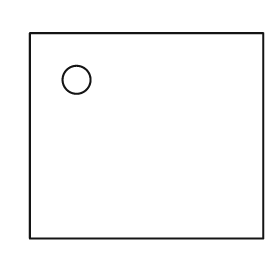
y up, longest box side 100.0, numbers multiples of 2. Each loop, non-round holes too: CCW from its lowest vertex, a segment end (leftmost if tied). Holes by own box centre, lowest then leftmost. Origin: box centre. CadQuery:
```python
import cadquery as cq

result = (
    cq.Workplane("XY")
    .moveTo(-50.0, -44.0)
    .lineTo(50.0, -44.0)
    .lineTo(50.0, 44.0)
    .lineTo(-50.0, 44.0)
    .close()
    .moveTo(-30.0, 24.0)
    .circle(6.0)
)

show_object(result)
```